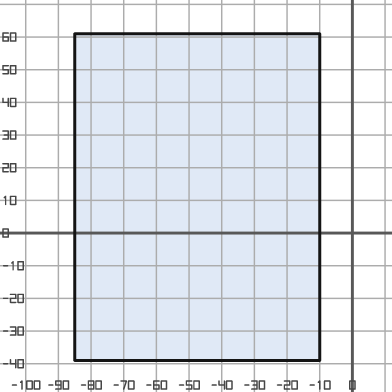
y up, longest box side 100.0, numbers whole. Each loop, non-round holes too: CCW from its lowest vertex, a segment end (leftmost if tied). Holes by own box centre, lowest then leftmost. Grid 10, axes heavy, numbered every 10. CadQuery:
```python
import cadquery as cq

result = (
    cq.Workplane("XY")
    .moveTo(-85.0, -39.0)
    .lineTo(-10.0, -39.0)
    .lineTo(-10.0, 61.0)
    .lineTo(-85.0, 61.0)
    .close()
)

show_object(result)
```